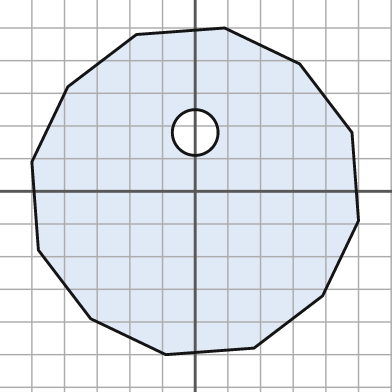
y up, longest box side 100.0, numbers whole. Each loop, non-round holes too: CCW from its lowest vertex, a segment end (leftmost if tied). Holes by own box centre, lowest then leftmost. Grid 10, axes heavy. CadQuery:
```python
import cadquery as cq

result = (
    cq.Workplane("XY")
    .moveTo(-9.0, -50.0)
    .lineTo(18.0, -48.0)
    .lineTo(39.0, -32.0)
    .lineTo(50.0, -9.0)
    .lineTo(48.0, 18.0)
    .lineTo(32.0, 39.0)
    .lineTo(9.0, 50.0)
    .lineTo(-18.0, 48.0)
    .lineTo(-39.0, 32.0)
    .lineTo(-50.0, 9.0)
    .lineTo(-48.0, -18.0)
    .lineTo(-32.0, -39.0)
    .close()
    .moveTo(0.0, 18.0)
    .circle(7.0)
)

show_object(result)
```